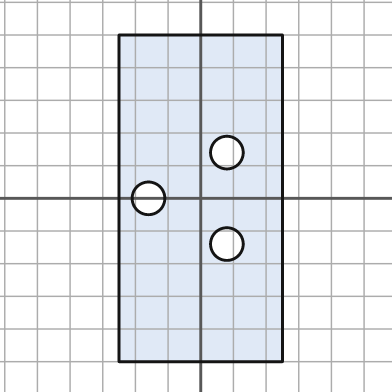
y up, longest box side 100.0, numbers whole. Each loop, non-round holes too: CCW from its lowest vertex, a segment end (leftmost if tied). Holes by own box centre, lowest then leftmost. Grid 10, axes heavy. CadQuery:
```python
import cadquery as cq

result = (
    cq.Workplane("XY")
    .moveTo(-25.0, -50.0)
    .lineTo(25.0, -50.0)
    .lineTo(25.0, 50.0)
    .lineTo(-25.0, 50.0)
    .close()
    .moveTo(8.0, -14.0)
    .circle(5.0)
    .moveTo(-16.0, 0.0)
    .circle(5.0)
    .moveTo(8.0, 14.0)
    .circle(5.0)
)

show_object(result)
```